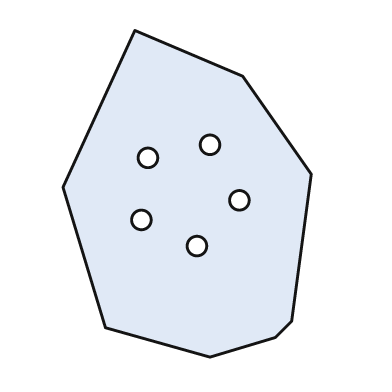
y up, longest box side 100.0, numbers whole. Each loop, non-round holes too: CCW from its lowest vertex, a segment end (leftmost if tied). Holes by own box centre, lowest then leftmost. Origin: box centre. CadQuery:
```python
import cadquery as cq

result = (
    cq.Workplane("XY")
    .moveTo(7.0, -50.0)
    .lineTo(27.0, -44.0)
    .lineTo(32.0, -39.0)
    .lineTo(38.0, 6.0)
    .lineTo(17.0, 36.0)
    .lineTo(-16.0, 50.0)
    .lineTo(-38.0, 2.0)
    .lineTo(-25.0, -41.0)
    .close()
    .moveTo(3.0, -16.0)
    .circle(3.0)
    .moveTo(-14.0, -8.0)
    .circle(3.0)
    .moveTo(16.0, -2.0)
    .circle(3.0)
    .moveTo(-12.0, 11.0)
    .circle(3.0)
    .moveTo(7.0, 15.0)
    .circle(3.0)
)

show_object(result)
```